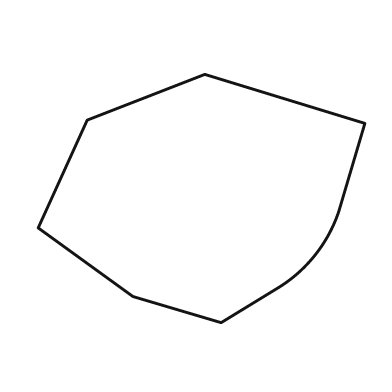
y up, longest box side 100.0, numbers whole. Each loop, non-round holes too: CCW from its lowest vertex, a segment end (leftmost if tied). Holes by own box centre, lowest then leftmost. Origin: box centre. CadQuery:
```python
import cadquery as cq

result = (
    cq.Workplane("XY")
    .moveTo(6.0, -38.0)
    .lineTo(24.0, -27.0)
    .threePointArc((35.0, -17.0), (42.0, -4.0))
    .lineTo(50.0, 23.0)
    .lineTo(1.0, 38.0)
    .lineTo(-35.0, 24.0)
    .lineTo(-50.0, -9.0)
    .lineTo(-21.0, -30.0)
    .close()
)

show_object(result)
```